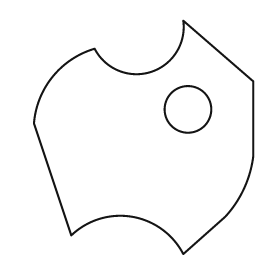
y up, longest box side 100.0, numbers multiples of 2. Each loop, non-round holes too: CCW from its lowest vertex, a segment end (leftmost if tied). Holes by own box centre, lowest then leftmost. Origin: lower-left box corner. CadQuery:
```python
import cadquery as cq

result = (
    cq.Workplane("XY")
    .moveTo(64.0, 0.0)
    .lineTo(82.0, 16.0)
    .threePointArc((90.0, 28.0), (94.0, 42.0))
    .lineTo(94.0, 74.0)
    .lineTo(64.0, 100.0)
    .threePointArc((50.0, 78.0), (26.0, 88.0))
    .threePointArc((8.0, 76.0), (0.0, 56.0))
    .lineTo(16.0, 8.0)
    .threePointArc((42.0, 16.0), (64.0, 0.0))
    .close()
    .moveTo(66.0, 62.0)
    .circle(10.0)
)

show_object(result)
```